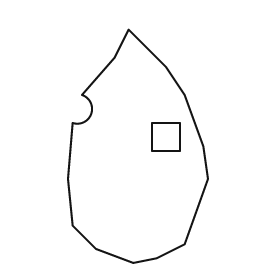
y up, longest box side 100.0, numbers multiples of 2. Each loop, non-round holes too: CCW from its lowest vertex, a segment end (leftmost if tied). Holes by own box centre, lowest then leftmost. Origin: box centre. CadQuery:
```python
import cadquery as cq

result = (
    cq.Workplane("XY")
    .moveTo(-2.0, -50.0)
    .lineTo(8.0, -48.0)
    .lineTo(20.0, -42.0)
    .lineTo(30.0, -14.0)
    .lineTo(28.0, 0.0)
    .lineTo(20.0, 22.0)
    .lineTo(12.0, 34.0)
    .lineTo(-4.0, 50.0)
    .lineTo(-10.0, 38.0)
    .lineTo(-24.0, 22.0)
    .threePointArc((-20.0, 14.0), (-28.0, 10.0))
    .lineTo(-30.0, -14.0)
    .lineTo(-28.0, -34.0)
    .lineTo(-18.0, -44.0)
    .close()
    .moveTo(6.0, -2.0)
    .lineTo(18.0, -2.0)
    .lineTo(18.0, 10.0)
    .lineTo(6.0, 10.0)
    .close()
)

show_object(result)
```